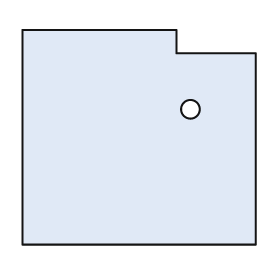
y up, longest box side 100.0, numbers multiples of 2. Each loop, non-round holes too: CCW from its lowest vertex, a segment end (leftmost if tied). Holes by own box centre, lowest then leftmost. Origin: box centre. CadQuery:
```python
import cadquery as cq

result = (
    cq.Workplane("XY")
    .moveTo(-50.0, -46.0)
    .lineTo(50.0, -46.0)
    .lineTo(50.0, 36.0)
    .lineTo(16.0, 36.0)
    .lineTo(16.0, 46.0)
    .lineTo(-50.0, 46.0)
    .close()
    .moveTo(22.0, 12.0)
    .circle(4.0)
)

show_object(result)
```